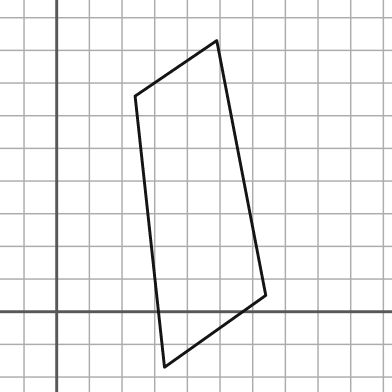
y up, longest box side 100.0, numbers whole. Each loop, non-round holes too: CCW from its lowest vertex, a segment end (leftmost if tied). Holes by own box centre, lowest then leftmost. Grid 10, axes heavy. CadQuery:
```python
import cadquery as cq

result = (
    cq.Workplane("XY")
    .moveTo(33.0, -17.0)
    .lineTo(64.0, 5.0)
    .lineTo(49.0, 83.0)
    .lineTo(24.0, 66.0)
    .close()
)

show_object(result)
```